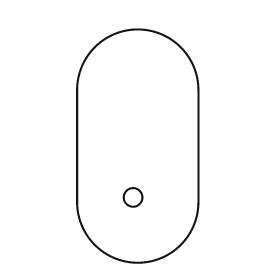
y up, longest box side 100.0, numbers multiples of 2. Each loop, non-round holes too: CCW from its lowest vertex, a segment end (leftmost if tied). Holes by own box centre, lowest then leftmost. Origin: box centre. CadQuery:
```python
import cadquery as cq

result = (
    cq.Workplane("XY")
    .moveTo(-26.0, -24.0)
    .threePointArc((0.0, -50.0), (26.0, -24.0))
    .lineTo(26.0, 24.0)
    .threePointArc((0.0, 50.0), (-26.0, 24.0))
    .close()
    .moveTo(-2.0, -22.0)
    .circle(4.0)
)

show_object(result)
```